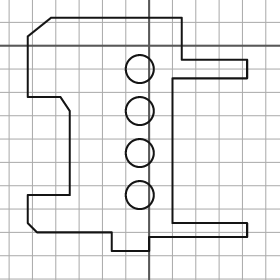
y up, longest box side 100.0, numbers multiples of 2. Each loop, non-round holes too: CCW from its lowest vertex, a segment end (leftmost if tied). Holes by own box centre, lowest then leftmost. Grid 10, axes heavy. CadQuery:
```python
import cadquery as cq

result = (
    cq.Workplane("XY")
    .moveTo(-16.0, -88.0)
    .lineTo(0.0, -88.0)
    .lineTo(0.0, -82.0)
    .lineTo(42.0, -82.0)
    .lineTo(42.0, -76.0)
    .lineTo(10.0, -76.0)
    .lineTo(10.0, -14.0)
    .lineTo(42.0, -14.0)
    .lineTo(42.0, -6.0)
    .lineTo(14.0, -6.0)
    .lineTo(14.0, 12.0)
    .lineTo(-42.0, 12.0)
    .lineTo(-52.0, 4.0)
    .lineTo(-52.0, -22.0)
    .lineTo(-38.0, -22.0)
    .lineTo(-34.0, -28.0)
    .lineTo(-34.0, -64.0)
    .lineTo(-52.0, -64.0)
    .lineTo(-52.0, -76.0)
    .lineTo(-48.0, -80.0)
    .lineTo(-16.0, -80.0)
    .close()
    .moveTo(-4.0, -64.0)
    .circle(6.0)
    .moveTo(-4.0, -46.0)
    .circle(6.0)
    .moveTo(-4.0, -28.0)
    .circle(6.0)
    .moveTo(-4.0, -10.0)
    .circle(6.0)
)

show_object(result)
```